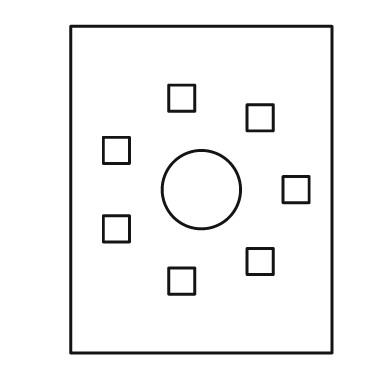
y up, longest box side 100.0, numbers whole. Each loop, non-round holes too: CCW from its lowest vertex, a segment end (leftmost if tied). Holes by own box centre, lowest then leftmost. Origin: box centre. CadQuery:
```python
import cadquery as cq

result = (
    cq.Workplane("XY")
    .moveTo(-40.0, -50.0)
    .lineTo(40.0, -50.0)
    .lineTo(40.0, 50.0)
    .lineTo(-40.0, 50.0)
    .close()
    .moveTo(-10.0, -32.0)
    .lineTo(-2.0, -32.0)
    .lineTo(-2.0, -24.0)
    .lineTo(-10.0, -24.0)
    .close()
    .moveTo(14.0, -26.0)
    .lineTo(22.0, -26.0)
    .lineTo(22.0, -18.0)
    .lineTo(14.0, -18.0)
    .close()
    .moveTo(-30.0, -16.0)
    .lineTo(-22.0, -16.0)
    .lineTo(-22.0, -8.0)
    .lineTo(-30.0, -8.0)
    .close()
    .moveTo(0.0, 0.0)
    .circle(12.0)
    .moveTo(25.0, -4.0)
    .lineTo(33.0, -4.0)
    .lineTo(33.0, 4.0)
    .lineTo(25.0, 4.0)
    .close()
    .moveTo(-30.0, 8.0)
    .lineTo(-22.0, 8.0)
    .lineTo(-22.0, 16.0)
    .lineTo(-30.0, 16.0)
    .close()
    .moveTo(14.0, 18.0)
    .lineTo(22.0, 18.0)
    .lineTo(22.0, 26.0)
    .lineTo(14.0, 26.0)
    .close()
    .moveTo(-10.0, 24.0)
    .lineTo(-2.0, 24.0)
    .lineTo(-2.0, 32.0)
    .lineTo(-10.0, 32.0)
    .close()
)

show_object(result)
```